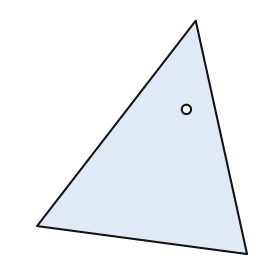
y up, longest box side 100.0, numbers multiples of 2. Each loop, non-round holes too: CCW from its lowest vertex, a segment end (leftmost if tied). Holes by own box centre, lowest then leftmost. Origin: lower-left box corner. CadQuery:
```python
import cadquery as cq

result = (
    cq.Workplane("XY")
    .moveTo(90.0, 0.0)
    .lineTo(68.0, 100.0)
    .lineTo(0.0, 12.0)
    .close()
    .moveTo(64.0, 62.0)
    .circle(2.0)
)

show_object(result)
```